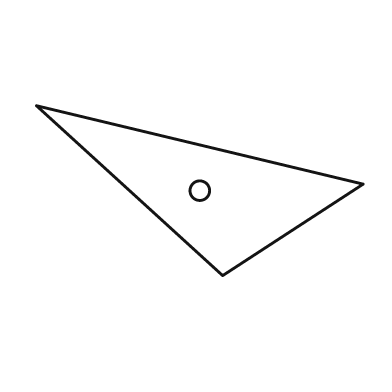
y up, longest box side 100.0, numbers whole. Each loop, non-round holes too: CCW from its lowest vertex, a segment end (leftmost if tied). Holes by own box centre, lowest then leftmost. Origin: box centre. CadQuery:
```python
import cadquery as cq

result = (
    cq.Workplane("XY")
    .moveTo(7.0, -26.0)
    .lineTo(50.0, 2.0)
    .lineTo(-50.0, 26.0)
    .close()
    .moveTo(0.0, 0.0)
    .circle(3.0)
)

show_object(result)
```